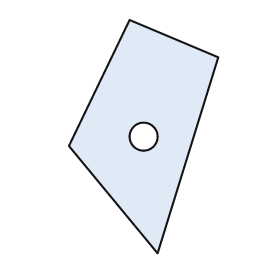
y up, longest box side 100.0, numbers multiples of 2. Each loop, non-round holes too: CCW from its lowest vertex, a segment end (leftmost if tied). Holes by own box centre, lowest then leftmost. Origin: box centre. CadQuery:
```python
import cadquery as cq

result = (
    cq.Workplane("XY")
    .moveTo(6.0, -50.0)
    .lineTo(32.0, 34.0)
    .lineTo(-6.0, 50.0)
    .lineTo(-32.0, -4.0)
    .close()
    .moveTo(0.0, 0.0)
    .circle(6.0)
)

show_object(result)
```